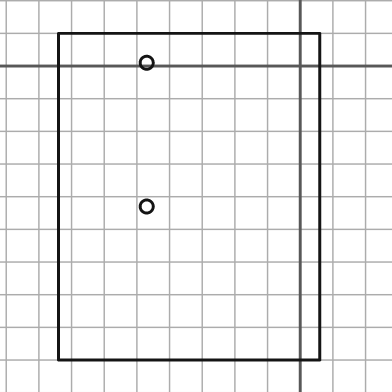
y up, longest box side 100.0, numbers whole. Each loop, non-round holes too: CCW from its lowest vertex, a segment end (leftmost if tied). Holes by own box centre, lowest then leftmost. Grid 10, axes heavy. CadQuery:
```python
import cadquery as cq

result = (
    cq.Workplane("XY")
    .moveTo(-74.0, -90.0)
    .lineTo(6.0, -90.0)
    .lineTo(6.0, 10.0)
    .lineTo(-74.0, 10.0)
    .close()
    .moveTo(-47.0, -43.0)
    .circle(2.0)
    .moveTo(-47.0, 1.0)
    .circle(2.0)
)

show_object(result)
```